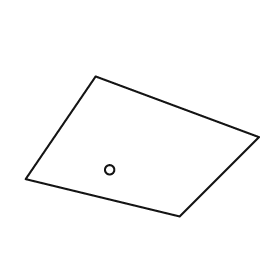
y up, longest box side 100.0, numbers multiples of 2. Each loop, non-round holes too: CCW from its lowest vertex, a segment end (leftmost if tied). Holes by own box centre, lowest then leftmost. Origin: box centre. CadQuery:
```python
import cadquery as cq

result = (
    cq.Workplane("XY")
    .moveTo(16.0, -30.0)
    .lineTo(50.0, 4.0)
    .lineTo(-20.0, 30.0)
    .lineTo(-50.0, -14.0)
    .close()
    .moveTo(-14.0, -10.0)
    .circle(2.0)
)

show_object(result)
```